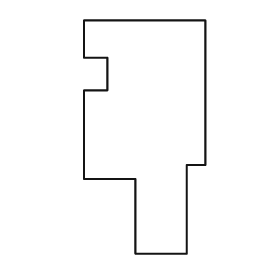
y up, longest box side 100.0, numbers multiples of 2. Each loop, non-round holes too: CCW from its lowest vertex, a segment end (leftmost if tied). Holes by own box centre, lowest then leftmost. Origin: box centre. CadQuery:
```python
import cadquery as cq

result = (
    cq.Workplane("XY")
    .moveTo(-4.0, -50.0)
    .lineTo(18.0, -50.0)
    .lineTo(18.0, -12.0)
    .lineTo(26.0, -12.0)
    .lineTo(26.0, 50.0)
    .lineTo(-26.0, 50.0)
    .lineTo(-26.0, 34.0)
    .lineTo(-16.0, 34.0)
    .lineTo(-16.0, 20.0)
    .lineTo(-26.0, 20.0)
    .lineTo(-26.0, -18.0)
    .lineTo(-4.0, -18.0)
    .close()
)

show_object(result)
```